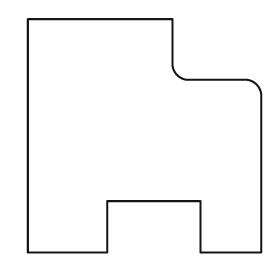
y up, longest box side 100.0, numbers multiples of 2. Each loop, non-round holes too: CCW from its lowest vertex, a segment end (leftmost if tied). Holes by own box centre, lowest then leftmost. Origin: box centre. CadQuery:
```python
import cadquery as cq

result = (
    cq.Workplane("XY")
    .moveTo(-50.0, -50.0)
    .lineTo(-16.0, -50.0)
    .lineTo(-16.0, -28.0)
    .lineTo(24.0, -28.0)
    .lineTo(24.0, -50.0)
    .lineTo(50.0, -50.0)
    .lineTo(50.0, 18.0)
    .threePointArc((48.0, 22.0), (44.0, 24.0))
    .lineTo(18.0, 24.0)
    .threePointArc((14.0, 26.0), (12.0, 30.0))
    .lineTo(12.0, 50.0)
    .lineTo(-50.0, 50.0)
    .close()
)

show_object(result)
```